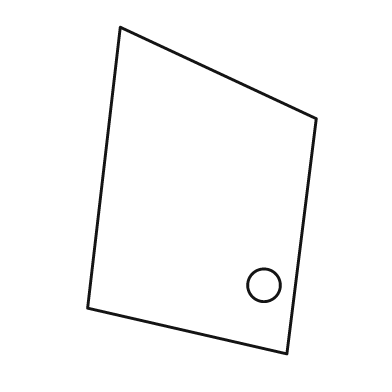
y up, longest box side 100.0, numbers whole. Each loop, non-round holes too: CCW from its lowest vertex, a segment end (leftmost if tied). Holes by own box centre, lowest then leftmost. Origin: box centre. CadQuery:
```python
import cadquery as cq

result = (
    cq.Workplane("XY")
    .moveTo(26.0, -50.0)
    .lineTo(35.0, 22.0)
    .lineTo(-25.0, 50.0)
    .lineTo(-35.0, -36.0)
    .close()
    .moveTo(19.0, -29.0)
    .circle(5.0)
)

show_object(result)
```